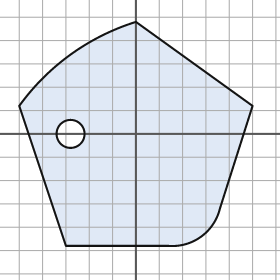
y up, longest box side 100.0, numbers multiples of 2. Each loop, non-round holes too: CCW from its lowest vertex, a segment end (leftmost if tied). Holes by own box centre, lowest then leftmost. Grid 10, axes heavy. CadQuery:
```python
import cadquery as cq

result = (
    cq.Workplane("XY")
    .moveTo(-30.0, -48.0)
    .lineTo(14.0, -48.0)
    .threePointArc((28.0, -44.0), (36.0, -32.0))
    .lineTo(50.0, 12.0)
    .lineTo(0.0, 48.0)
    .threePointArc((-28.0, 34.0), (-50.0, 12.0))
    .close()
    .moveTo(-28.0, 0.0)
    .circle(6.0)
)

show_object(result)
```